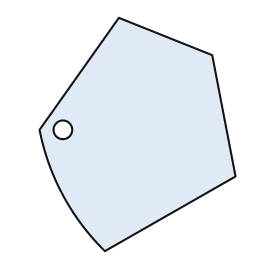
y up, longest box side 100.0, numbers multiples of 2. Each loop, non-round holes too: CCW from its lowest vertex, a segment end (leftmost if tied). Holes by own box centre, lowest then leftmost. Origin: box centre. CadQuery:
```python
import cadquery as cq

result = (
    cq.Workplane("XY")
    .moveTo(-14.0, -50.0)
    .lineTo(42.0, -18.0)
    .lineTo(32.0, 34.0)
    .lineTo(-8.0, 50.0)
    .lineTo(-42.0, 2.0)
    .threePointArc((-32.0, -26.0), (-14.0, -50.0))
    .close()
    .moveTo(-32.0, 2.0)
    .circle(4.0)
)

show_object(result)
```